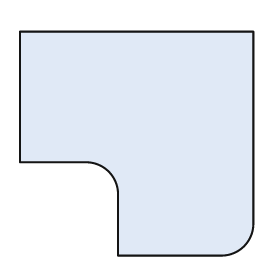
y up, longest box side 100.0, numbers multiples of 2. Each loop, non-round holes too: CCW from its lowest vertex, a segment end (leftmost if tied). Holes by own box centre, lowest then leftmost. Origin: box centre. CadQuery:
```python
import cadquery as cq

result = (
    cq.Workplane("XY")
    .moveTo(-8.0, -48.0)
    .lineTo(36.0, -48.0)
    .threePointArc((46.0, -44.0), (50.0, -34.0))
    .lineTo(50.0, 48.0)
    .lineTo(-50.0, 48.0)
    .lineTo(-50.0, -8.0)
    .lineTo(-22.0, -8.0)
    .threePointArc((-12.0, -12.0), (-8.0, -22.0))
    .close()
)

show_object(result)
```